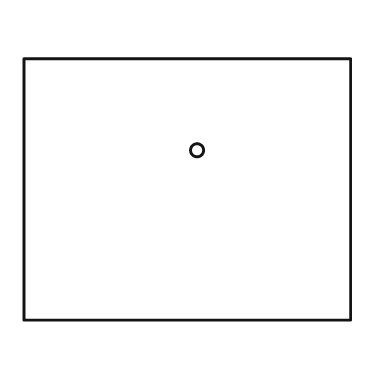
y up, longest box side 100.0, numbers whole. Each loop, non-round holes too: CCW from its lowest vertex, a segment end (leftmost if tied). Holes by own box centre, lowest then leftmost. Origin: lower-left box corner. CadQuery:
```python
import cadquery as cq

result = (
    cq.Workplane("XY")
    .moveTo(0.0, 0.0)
    .lineTo(100.0, 0.0)
    .lineTo(100.0, 80.0)
    .lineTo(0.0, 80.0)
    .close()
    .moveTo(53.0, 52.0)
    .circle(2.0)
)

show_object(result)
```